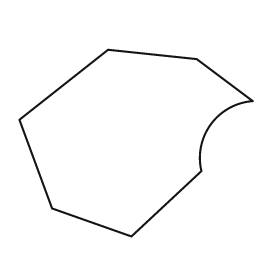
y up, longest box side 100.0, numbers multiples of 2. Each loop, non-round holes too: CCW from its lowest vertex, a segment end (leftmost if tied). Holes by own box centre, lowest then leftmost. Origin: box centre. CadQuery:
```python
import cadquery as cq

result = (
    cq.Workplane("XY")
    .moveTo(-2.0, -40.0)
    .lineTo(28.0, -12.0)
    .threePointArc((32.0, 8.0), (50.0, 18.0))
    .lineTo(26.0, 36.0)
    .lineTo(-12.0, 40.0)
    .lineTo(-50.0, 10.0)
    .lineTo(-36.0, -28.0)
    .close()
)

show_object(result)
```